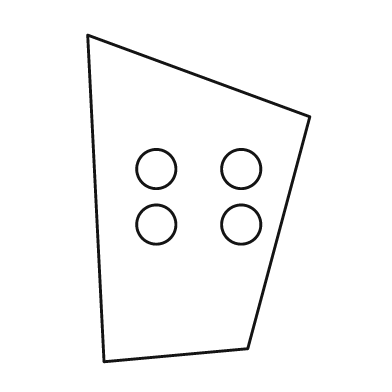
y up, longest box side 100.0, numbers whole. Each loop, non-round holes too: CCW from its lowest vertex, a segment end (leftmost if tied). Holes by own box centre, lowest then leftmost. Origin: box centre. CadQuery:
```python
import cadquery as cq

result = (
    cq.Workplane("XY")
    .moveTo(-29.0, -50.0)
    .lineTo(15.0, -46.0)
    .lineTo(34.0, 25.0)
    .lineTo(-34.0, 50.0)
    .close()
    .moveTo(-13.0, -8.0)
    .circle(6.0)
    .moveTo(13.0, -8.0)
    .circle(6.0)
    .moveTo(-13.0, 9.0)
    .circle(6.0)
    .moveTo(13.0, 9.0)
    .circle(6.0)
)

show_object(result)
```